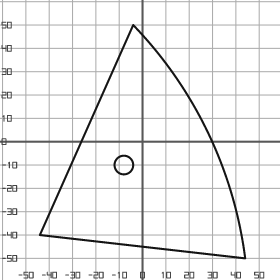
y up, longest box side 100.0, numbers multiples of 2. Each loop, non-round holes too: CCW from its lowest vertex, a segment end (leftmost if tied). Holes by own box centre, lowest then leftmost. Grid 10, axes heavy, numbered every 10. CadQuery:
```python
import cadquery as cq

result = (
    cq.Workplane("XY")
    .moveTo(44.0, -50.0)
    .threePointArc((28.0, 4.0), (-4.0, 50.0))
    .lineTo(-44.0, -40.0)
    .close()
    .moveTo(-8.0, -10.0)
    .circle(4.0)
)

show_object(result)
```